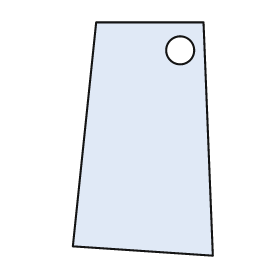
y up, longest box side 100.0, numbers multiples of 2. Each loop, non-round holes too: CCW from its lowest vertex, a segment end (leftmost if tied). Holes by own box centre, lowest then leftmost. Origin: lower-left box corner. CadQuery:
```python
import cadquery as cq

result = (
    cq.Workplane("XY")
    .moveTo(60.0, 0.0)
    .lineTo(56.0, 100.0)
    .lineTo(10.0, 100.0)
    .lineTo(0.0, 4.0)
    .close()
    .moveTo(46.0, 88.0)
    .circle(6.0)
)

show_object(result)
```